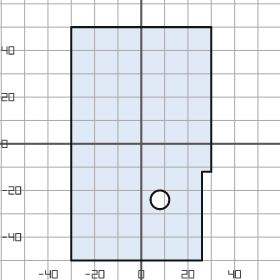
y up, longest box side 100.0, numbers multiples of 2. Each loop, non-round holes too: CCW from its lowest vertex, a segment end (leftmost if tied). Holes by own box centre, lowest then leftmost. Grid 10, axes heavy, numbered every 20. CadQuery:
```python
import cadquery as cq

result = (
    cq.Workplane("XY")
    .moveTo(-30.0, -50.0)
    .lineTo(26.0, -50.0)
    .lineTo(26.0, -12.0)
    .lineTo(30.0, -12.0)
    .lineTo(30.0, 50.0)
    .lineTo(-30.0, 50.0)
    .close()
    .moveTo(8.0, -24.0)
    .circle(4.0)
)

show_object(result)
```